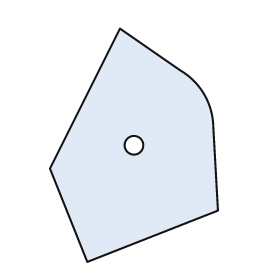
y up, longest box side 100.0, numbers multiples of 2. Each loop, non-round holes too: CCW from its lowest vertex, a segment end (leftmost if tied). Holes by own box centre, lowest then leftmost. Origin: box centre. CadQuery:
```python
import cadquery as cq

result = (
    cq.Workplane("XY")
    .moveTo(-20.0, -50.0)
    .lineTo(36.0, -28.0)
    .lineTo(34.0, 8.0)
    .threePointArc((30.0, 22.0), (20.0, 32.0))
    .lineTo(-6.0, 50.0)
    .lineTo(-36.0, -10.0)
    .close()
    .moveTo(0.0, 0.0)
    .circle(4.0)
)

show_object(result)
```